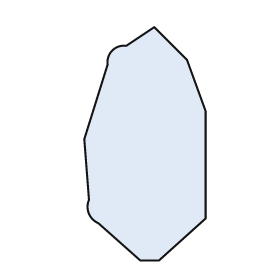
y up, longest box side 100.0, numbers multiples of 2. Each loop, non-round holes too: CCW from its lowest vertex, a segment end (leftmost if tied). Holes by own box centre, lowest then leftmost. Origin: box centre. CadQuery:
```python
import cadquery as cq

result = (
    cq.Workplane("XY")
    .moveTo(-2.0, -50.0)
    .lineTo(6.0, -50.0)
    .lineTo(26.0, -32.0)
    .lineTo(26.0, 14.0)
    .lineTo(18.0, 36.0)
    .lineTo(4.0, 50.0)
    .lineTo(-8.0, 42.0)
    .threePointArc((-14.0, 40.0), (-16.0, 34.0))
    .lineTo(-26.0, 2.0)
    .lineTo(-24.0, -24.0)
    .threePointArc((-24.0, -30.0), (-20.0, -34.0))
    .close()
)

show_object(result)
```